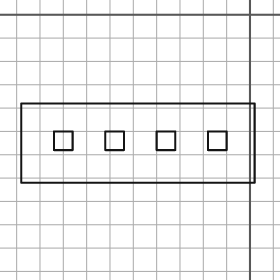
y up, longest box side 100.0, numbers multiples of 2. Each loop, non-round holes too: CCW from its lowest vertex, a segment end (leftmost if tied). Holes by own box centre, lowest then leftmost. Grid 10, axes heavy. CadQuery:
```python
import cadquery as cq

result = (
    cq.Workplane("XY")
    .moveTo(-98.0, -72.0)
    .lineTo(2.0, -72.0)
    .lineTo(2.0, -38.0)
    .lineTo(-98.0, -38.0)
    .close()
    .moveTo(-84.0, -58.0)
    .lineTo(-76.0, -58.0)
    .lineTo(-76.0, -50.0)
    .lineTo(-84.0, -50.0)
    .close()
    .moveTo(-62.0, -58.0)
    .lineTo(-54.0, -58.0)
    .lineTo(-54.0, -50.0)
    .lineTo(-62.0, -50.0)
    .close()
    .moveTo(-40.0, -58.0)
    .lineTo(-32.0, -58.0)
    .lineTo(-32.0, -50.0)
    .lineTo(-40.0, -50.0)
    .close()
    .moveTo(-18.0, -58.0)
    .lineTo(-10.0, -58.0)
    .lineTo(-10.0, -50.0)
    .lineTo(-18.0, -50.0)
    .close()
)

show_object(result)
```